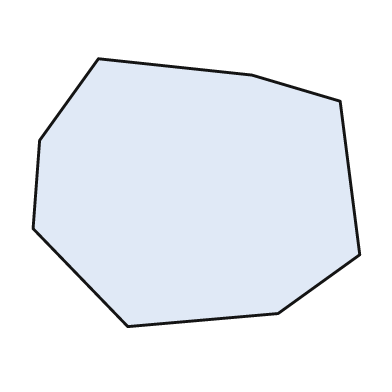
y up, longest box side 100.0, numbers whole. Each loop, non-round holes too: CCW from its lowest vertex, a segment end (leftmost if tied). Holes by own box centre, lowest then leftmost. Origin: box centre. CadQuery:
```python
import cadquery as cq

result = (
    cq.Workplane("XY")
    .moveTo(-21.0, -41.0)
    .lineTo(25.0, -37.0)
    .lineTo(50.0, -19.0)
    .lineTo(44.0, 28.0)
    .lineTo(17.0, 36.0)
    .lineTo(-30.0, 41.0)
    .lineTo(-48.0, 16.0)
    .lineTo(-50.0, -11.0)
    .close()
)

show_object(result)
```